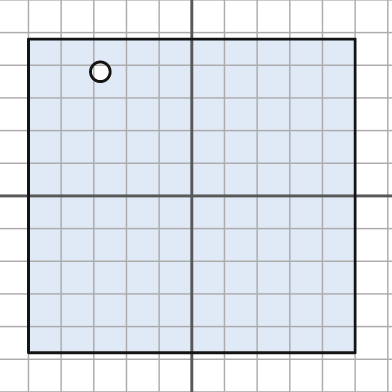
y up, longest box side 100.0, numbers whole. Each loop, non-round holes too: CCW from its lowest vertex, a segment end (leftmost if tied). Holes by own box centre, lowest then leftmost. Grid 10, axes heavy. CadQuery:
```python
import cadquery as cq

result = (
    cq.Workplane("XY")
    .moveTo(-50.0, -48.0)
    .lineTo(50.0, -48.0)
    .lineTo(50.0, 48.0)
    .lineTo(-50.0, 48.0)
    .close()
    .moveTo(-28.0, 38.0)
    .circle(3.0)
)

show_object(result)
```